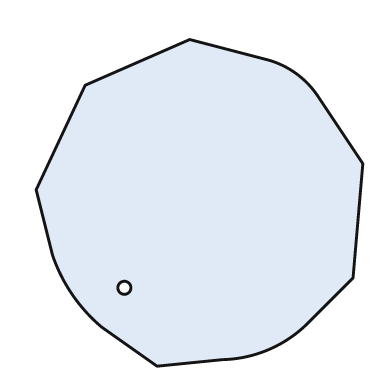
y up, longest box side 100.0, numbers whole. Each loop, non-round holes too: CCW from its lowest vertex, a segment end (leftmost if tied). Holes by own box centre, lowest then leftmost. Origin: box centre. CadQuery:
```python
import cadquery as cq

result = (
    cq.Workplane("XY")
    .moveTo(-13.0, -50.0)
    .lineTo(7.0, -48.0)
    .threePointArc((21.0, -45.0), (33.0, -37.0))
    .lineTo(47.0, -23.0)
    .lineTo(50.0, 12.0)
    .lineTo(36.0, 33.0)
    .threePointArc((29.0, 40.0), (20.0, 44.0))
    .lineTo(-3.0, 50.0)
    .lineTo(-35.0, 36.0)
    .lineTo(-50.0, 4.0)
    .lineTo(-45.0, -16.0)
    .threePointArc((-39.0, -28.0), (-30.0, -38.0))
    .close()
    .moveTo(-23.0, -26.0)
    .circle(2.0)
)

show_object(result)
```